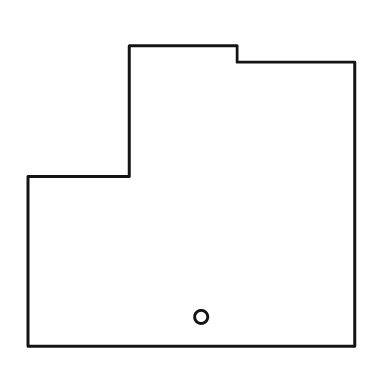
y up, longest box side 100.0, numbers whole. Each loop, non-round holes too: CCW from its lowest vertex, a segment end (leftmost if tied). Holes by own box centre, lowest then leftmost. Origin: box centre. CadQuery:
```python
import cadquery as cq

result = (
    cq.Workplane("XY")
    .moveTo(-50.0, -46.0)
    .lineTo(50.0, -46.0)
    .lineTo(50.0, 41.0)
    .lineTo(14.0, 41.0)
    .lineTo(14.0, 46.0)
    .lineTo(-19.0, 46.0)
    .lineTo(-19.0, 6.0)
    .lineTo(-50.0, 6.0)
    .close()
    .moveTo(3.0, -37.0)
    .circle(2.0)
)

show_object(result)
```